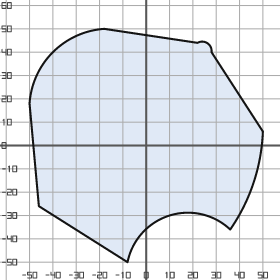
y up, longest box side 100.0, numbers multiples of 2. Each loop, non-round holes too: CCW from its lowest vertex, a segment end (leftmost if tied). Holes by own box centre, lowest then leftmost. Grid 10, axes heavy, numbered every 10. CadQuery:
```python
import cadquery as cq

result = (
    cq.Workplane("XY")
    .moveTo(-8.0, -50.0)
    .threePointArc((10.0, -30.0), (36.0, -36.0))
    .threePointArc((46.0, -16.0), (50.0, 6.0))
    .lineTo(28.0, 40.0)
    .threePointArc((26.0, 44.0), (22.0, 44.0))
    .lineTo(-18.0, 50.0)
    .threePointArc((-40.0, 40.0), (-50.0, 18.0))
    .lineTo(-46.0, -26.0)
    .close()
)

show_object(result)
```